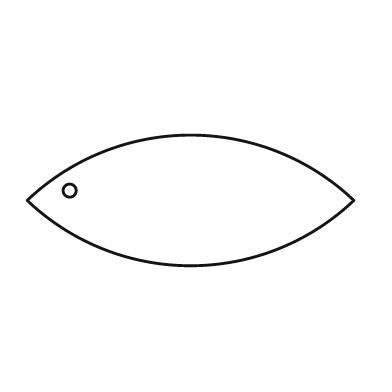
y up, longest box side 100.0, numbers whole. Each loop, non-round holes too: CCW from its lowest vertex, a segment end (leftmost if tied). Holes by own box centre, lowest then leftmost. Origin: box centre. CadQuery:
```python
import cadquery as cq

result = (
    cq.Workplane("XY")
    .moveTo(-50.0, 0.0)
    .threePointArc((0.0, -20.0), (50.0, 0.0))
    .threePointArc((0.0, 20.0), (-50.0, 0.0))
    .close()
    .moveTo(-37.0, 3.0)
    .circle(2.0)
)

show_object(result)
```